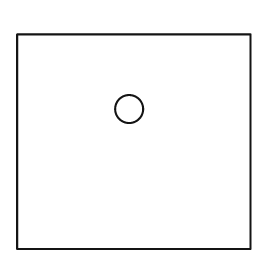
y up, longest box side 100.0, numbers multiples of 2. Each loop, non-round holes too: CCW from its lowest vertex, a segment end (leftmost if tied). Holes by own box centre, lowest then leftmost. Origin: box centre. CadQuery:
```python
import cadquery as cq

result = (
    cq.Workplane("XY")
    .moveTo(-50.0, -46.0)
    .lineTo(50.0, -46.0)
    .lineTo(50.0, 46.0)
    .lineTo(-50.0, 46.0)
    .close()
    .moveTo(-2.0, 14.0)
    .circle(6.0)
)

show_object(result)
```